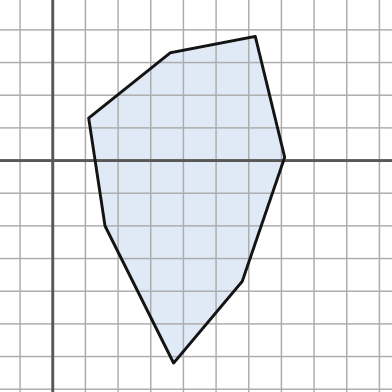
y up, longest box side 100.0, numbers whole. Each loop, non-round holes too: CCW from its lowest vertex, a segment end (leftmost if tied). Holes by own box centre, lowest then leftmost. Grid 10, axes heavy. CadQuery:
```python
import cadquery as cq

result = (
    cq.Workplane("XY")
    .moveTo(37.0, -62.0)
    .lineTo(58.0, -37.0)
    .lineTo(71.0, 1.0)
    .lineTo(62.0, 38.0)
    .lineTo(36.0, 33.0)
    .lineTo(11.0, 13.0)
    .lineTo(16.0, -20.0)
    .close()
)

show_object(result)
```